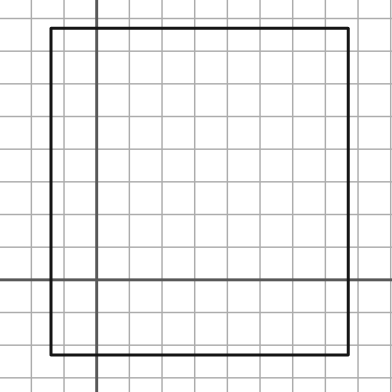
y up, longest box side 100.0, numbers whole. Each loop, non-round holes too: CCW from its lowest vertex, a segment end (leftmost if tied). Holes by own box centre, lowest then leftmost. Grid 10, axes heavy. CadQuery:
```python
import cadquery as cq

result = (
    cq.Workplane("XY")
    .moveTo(-14.0, -23.0)
    .lineTo(77.0, -23.0)
    .lineTo(77.0, 77.0)
    .lineTo(-14.0, 77.0)
    .close()
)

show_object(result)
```